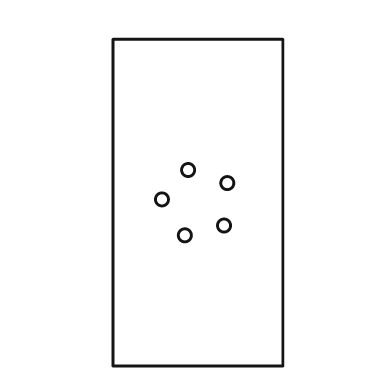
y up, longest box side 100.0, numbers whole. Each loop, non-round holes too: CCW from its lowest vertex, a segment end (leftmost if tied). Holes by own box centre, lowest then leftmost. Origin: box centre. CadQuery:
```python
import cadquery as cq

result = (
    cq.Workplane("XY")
    .moveTo(-26.0, -50.0)
    .lineTo(26.0, -50.0)
    .lineTo(26.0, 50.0)
    .lineTo(-26.0, 50.0)
    .close()
    .moveTo(-4.0, -10.0)
    .circle(2.0)
    .moveTo(8.0, -7.0)
    .circle(2.0)
    .moveTo(-11.0, 1.0)
    .circle(2.0)
    .moveTo(9.0, 6.0)
    .circle(2.0)
    .moveTo(-3.0, 10.0)
    .circle(2.0)
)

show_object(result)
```